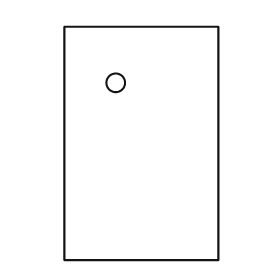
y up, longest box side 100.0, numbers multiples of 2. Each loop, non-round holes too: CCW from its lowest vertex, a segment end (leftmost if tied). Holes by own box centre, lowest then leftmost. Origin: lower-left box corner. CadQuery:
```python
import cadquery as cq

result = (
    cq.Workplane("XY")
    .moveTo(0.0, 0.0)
    .lineTo(66.0, 0.0)
    .lineTo(66.0, 100.0)
    .lineTo(0.0, 100.0)
    .close()
    .moveTo(22.0, 76.0)
    .circle(4.0)
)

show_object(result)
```